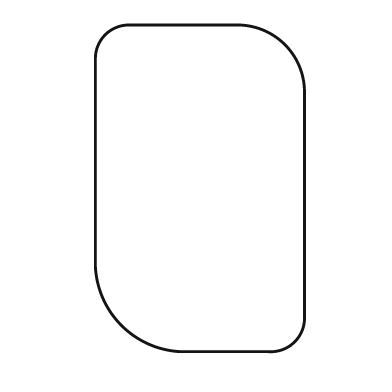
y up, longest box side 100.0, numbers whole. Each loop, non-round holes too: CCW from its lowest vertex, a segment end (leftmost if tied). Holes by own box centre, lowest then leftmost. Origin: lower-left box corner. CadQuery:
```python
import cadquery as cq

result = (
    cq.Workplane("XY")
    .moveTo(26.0, 0.0)
    .lineTo(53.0, 0.0)
    .threePointArc((61.0, 3.0), (64.0, 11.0))
    .lineTo(64.0, 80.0)
    .threePointArc((58.0, 94.0), (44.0, 100.0))
    .lineTo(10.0, 100.0)
    .threePointArc((3.0, 97.0), (0.0, 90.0))
    .lineTo(0.0, 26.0)
    .threePointArc((8.0, 8.0), (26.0, 0.0))
    .close()
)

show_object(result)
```